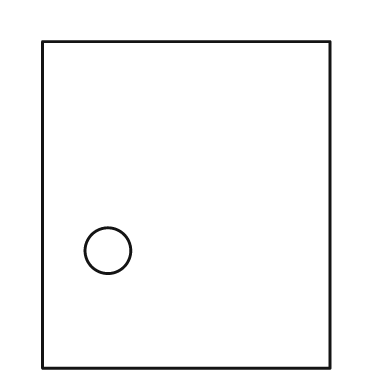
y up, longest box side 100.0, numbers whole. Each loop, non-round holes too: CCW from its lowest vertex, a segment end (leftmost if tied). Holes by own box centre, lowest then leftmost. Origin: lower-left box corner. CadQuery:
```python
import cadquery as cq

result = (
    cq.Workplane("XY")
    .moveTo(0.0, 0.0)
    .lineTo(88.0, 0.0)
    .lineTo(88.0, 100.0)
    .lineTo(0.0, 100.0)
    .close()
    .moveTo(20.0, 36.0)
    .circle(7.0)
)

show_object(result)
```